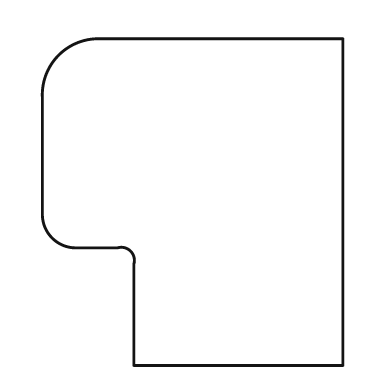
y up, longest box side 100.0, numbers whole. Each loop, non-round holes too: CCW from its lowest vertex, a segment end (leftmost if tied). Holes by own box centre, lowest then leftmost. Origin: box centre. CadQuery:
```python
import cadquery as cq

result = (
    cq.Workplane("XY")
    .moveTo(-18.0, -50.0)
    .lineTo(46.0, -50.0)
    .lineTo(46.0, 50.0)
    .lineTo(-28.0, 50.0)
    .threePointArc((-41.0, 45.0), (-46.0, 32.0))
    .lineTo(-46.0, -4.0)
    .threePointArc((-43.0, -11.0), (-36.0, -14.0))
    .lineTo(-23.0, -14.0)
    .threePointArc((-19.0, -15.0), (-18.0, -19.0))
    .close()
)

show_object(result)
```